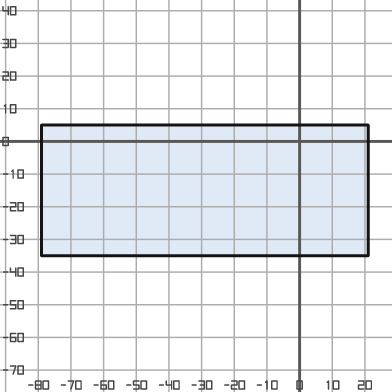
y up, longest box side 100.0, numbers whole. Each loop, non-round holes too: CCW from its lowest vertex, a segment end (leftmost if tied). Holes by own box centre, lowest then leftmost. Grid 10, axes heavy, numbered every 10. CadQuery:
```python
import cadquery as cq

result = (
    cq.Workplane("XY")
    .moveTo(-79.0, -35.0)
    .lineTo(21.0, -35.0)
    .lineTo(21.0, 5.0)
    .lineTo(-79.0, 5.0)
    .close()
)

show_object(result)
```